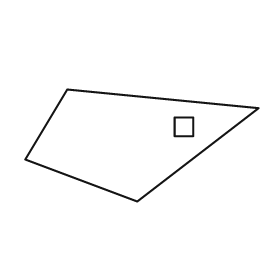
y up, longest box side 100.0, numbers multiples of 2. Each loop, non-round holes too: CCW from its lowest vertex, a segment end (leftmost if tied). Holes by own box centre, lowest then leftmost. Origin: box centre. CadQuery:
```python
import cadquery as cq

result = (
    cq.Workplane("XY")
    .moveTo(-2.0, -24.0)
    .lineTo(50.0, 16.0)
    .lineTo(-32.0, 24.0)
    .lineTo(-50.0, -6.0)
    .close()
    .moveTo(14.0, 4.0)
    .lineTo(22.0, 4.0)
    .lineTo(22.0, 12.0)
    .lineTo(14.0, 12.0)
    .close()
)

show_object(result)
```